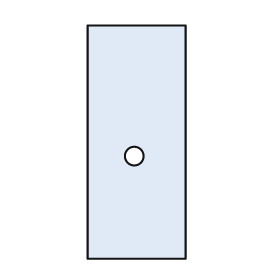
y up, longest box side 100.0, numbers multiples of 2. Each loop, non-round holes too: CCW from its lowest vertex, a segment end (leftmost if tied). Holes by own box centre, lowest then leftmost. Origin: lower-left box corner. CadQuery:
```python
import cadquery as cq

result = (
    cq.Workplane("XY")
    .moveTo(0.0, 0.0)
    .lineTo(42.0, 0.0)
    .lineTo(42.0, 100.0)
    .lineTo(0.0, 100.0)
    .close()
    .moveTo(20.0, 44.0)
    .circle(4.0)
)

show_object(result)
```